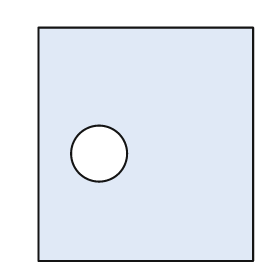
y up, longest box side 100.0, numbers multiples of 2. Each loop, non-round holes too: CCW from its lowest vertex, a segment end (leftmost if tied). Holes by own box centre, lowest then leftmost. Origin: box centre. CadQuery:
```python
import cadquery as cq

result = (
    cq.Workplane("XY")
    .moveTo(-46.0, -50.0)
    .lineTo(46.0, -50.0)
    .lineTo(46.0, 50.0)
    .lineTo(-46.0, 50.0)
    .close()
    .moveTo(-20.0, -4.0)
    .circle(12.0)
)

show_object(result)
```